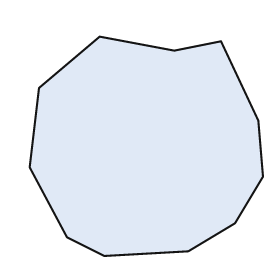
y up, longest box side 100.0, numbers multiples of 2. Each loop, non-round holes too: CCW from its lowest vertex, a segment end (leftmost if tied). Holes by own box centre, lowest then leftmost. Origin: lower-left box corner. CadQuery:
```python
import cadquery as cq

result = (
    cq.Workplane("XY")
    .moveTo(32.0, 0.0)
    .lineTo(68.0, 2.0)
    .lineTo(88.0, 14.0)
    .lineTo(100.0, 34.0)
    .lineTo(98.0, 58.0)
    .lineTo(82.0, 92.0)
    .lineTo(62.0, 88.0)
    .lineTo(30.0, 94.0)
    .lineTo(4.0, 72.0)
    .lineTo(0.0, 38.0)
    .lineTo(16.0, 8.0)
    .close()
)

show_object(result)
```